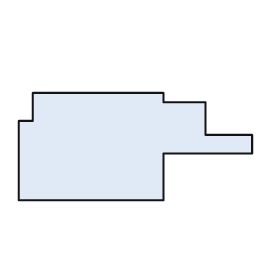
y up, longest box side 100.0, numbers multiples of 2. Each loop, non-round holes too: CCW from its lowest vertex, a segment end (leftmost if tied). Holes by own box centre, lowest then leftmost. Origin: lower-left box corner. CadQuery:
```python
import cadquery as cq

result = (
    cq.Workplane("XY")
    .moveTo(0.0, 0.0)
    .lineTo(62.0, 0.0)
    .lineTo(62.0, 20.0)
    .lineTo(100.0, 20.0)
    .lineTo(100.0, 28.0)
    .lineTo(80.0, 28.0)
    .lineTo(80.0, 42.0)
    .lineTo(62.0, 42.0)
    .lineTo(62.0, 46.0)
    .lineTo(6.0, 46.0)
    .lineTo(6.0, 34.0)
    .lineTo(0.0, 34.0)
    .close()
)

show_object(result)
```